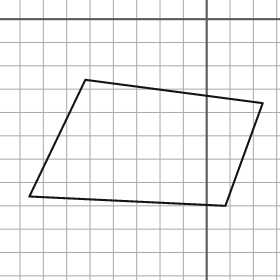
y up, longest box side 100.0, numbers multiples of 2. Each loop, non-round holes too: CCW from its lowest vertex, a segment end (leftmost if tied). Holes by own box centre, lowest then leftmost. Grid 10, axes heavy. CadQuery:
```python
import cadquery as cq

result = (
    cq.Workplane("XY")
    .moveTo(8.0, -80.0)
    .lineTo(24.0, -36.0)
    .lineTo(-52.0, -26.0)
    .lineTo(-76.0, -76.0)
    .close()
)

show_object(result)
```